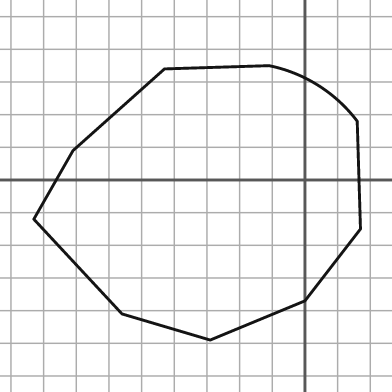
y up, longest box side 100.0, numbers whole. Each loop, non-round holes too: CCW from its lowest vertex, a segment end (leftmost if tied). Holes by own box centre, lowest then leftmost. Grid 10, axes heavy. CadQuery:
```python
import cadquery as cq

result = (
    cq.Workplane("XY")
    .moveTo(-29.0, -49.0)
    .lineTo(0.0, -37.0)
    .lineTo(17.0, -15.0)
    .lineTo(16.0, 18.0)
    .threePointArc((4.0, 29.0), (-11.0, 35.0))
    .lineTo(-43.0, 34.0)
    .lineTo(-71.0, 9.0)
    .lineTo(-83.0, -12.0)
    .lineTo(-56.0, -41.0)
    .close()
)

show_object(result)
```